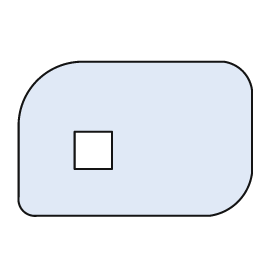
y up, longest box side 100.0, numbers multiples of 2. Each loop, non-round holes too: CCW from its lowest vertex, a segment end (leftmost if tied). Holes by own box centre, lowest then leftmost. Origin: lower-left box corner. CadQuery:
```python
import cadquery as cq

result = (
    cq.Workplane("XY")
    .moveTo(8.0, 0.0)
    .lineTo(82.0, 0.0)
    .threePointArc((94.0, 6.0), (100.0, 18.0))
    .lineTo(100.0, 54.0)
    .threePointArc((96.0, 62.0), (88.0, 66.0))
    .lineTo(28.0, 66.0)
    .threePointArc((8.0, 58.0), (0.0, 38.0))
    .lineTo(0.0, 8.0)
    .threePointArc((2.0, 2.0), (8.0, 0.0))
    .close()
    .moveTo(24.0, 20.0)
    .lineTo(40.0, 20.0)
    .lineTo(40.0, 36.0)
    .lineTo(24.0, 36.0)
    .close()
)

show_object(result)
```